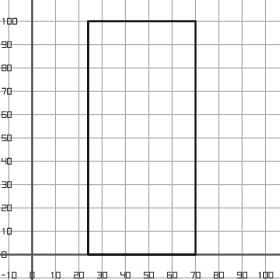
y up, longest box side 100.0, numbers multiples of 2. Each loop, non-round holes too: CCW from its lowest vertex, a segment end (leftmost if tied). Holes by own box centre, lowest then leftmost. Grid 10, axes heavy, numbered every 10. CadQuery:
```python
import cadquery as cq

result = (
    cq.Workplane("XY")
    .moveTo(24.0, 0.0)
    .lineTo(70.0, 0.0)
    .lineTo(70.0, 100.0)
    .lineTo(24.0, 100.0)
    .close()
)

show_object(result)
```